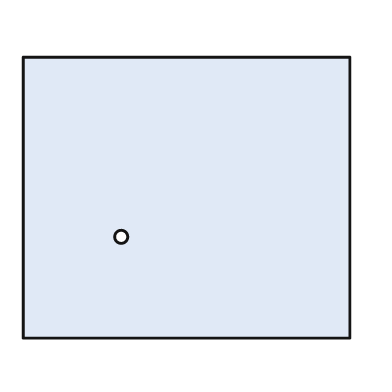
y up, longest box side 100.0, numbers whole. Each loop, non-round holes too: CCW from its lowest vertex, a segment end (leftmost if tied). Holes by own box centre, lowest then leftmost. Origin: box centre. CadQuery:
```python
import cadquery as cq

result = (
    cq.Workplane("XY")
    .moveTo(-50.0, -43.0)
    .lineTo(50.0, -43.0)
    .lineTo(50.0, 43.0)
    .lineTo(-50.0, 43.0)
    .close()
    .moveTo(-20.0, -12.0)
    .circle(2.0)
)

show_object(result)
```